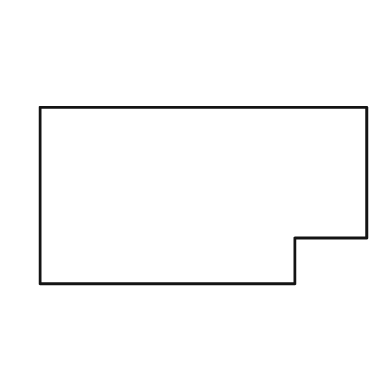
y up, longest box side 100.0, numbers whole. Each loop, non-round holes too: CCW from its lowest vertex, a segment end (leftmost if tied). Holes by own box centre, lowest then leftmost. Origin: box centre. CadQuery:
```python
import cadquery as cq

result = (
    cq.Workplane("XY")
    .moveTo(-50.0, -27.0)
    .lineTo(28.0, -27.0)
    .lineTo(28.0, -13.0)
    .lineTo(50.0, -13.0)
    .lineTo(50.0, 27.0)
    .lineTo(-50.0, 27.0)
    .close()
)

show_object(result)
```